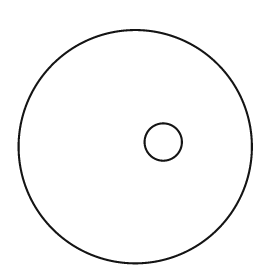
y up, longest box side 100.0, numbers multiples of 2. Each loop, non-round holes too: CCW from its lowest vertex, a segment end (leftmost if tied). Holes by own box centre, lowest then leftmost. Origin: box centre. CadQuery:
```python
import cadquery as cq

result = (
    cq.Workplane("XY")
    .moveTo(0.0, 0.0)
    .circle(50.0)
    .moveTo(12.0, 2.0)
    .circle(8.0)
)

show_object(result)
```